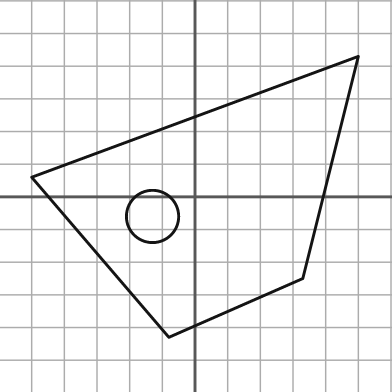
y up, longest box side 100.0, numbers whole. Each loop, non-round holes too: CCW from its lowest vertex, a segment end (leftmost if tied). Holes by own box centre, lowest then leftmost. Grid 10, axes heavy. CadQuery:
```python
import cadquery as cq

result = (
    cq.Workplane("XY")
    .moveTo(-8.0, -43.0)
    .lineTo(33.0, -25.0)
    .lineTo(50.0, 43.0)
    .lineTo(-50.0, 6.0)
    .close()
    .moveTo(-13.0, -6.0)
    .circle(8.0)
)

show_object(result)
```